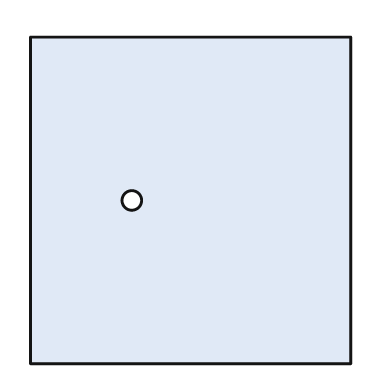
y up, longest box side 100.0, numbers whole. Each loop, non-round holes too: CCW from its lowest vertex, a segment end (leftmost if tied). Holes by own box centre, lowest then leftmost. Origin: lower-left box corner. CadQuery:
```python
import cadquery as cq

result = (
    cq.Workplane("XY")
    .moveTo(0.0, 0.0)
    .lineTo(98.0, 0.0)
    .lineTo(98.0, 100.0)
    .lineTo(0.0, 100.0)
    .close()
    .moveTo(31.0, 50.0)
    .circle(3.0)
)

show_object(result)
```